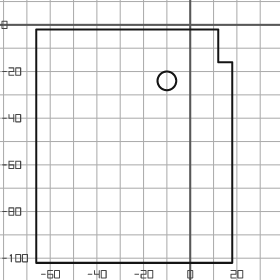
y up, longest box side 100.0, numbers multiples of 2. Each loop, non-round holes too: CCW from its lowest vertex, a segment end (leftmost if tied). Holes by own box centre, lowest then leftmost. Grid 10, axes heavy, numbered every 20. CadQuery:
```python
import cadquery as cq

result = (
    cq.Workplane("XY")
    .moveTo(-66.0, -102.0)
    .lineTo(18.0, -102.0)
    .lineTo(18.0, -16.0)
    .lineTo(12.0, -16.0)
    .lineTo(12.0, -2.0)
    .lineTo(-66.0, -2.0)
    .close()
    .moveTo(-10.0, -24.0)
    .circle(4.0)
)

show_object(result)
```